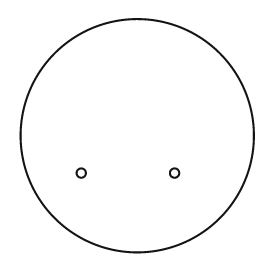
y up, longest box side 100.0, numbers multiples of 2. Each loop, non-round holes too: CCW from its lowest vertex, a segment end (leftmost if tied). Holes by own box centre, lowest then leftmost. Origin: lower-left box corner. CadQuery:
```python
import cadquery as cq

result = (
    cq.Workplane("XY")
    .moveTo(50.0, 50.0)
    .circle(50.0)
    .moveTo(26.0, 34.0)
    .circle(2.0)
    .moveTo(66.0, 34.0)
    .circle(2.0)
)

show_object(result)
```